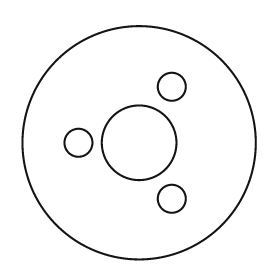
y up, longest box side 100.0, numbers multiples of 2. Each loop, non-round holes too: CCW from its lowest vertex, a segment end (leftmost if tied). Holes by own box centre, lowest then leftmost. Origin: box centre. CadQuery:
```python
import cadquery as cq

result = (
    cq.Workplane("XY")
    .moveTo(0.0, 0.0)
    .circle(50.0)
    .moveTo(14.0, -24.0)
    .circle(6.0)
    .moveTo(-26.0, 0.0)
    .circle(6.0)
    .moveTo(0.0, 0.0)
    .circle(16.0)
    .moveTo(14.0, 24.0)
    .circle(6.0)
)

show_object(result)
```